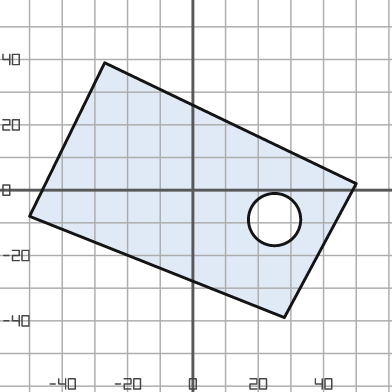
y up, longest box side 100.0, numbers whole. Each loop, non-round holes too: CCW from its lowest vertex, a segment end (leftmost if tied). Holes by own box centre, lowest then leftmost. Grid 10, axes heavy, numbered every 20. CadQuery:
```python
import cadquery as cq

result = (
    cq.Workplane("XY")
    .moveTo(28.0, -39.0)
    .lineTo(50.0, 2.0)
    .lineTo(-27.0, 39.0)
    .lineTo(-50.0, -8.0)
    .close()
    .moveTo(25.0, -9.0)
    .circle(8.0)
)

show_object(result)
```